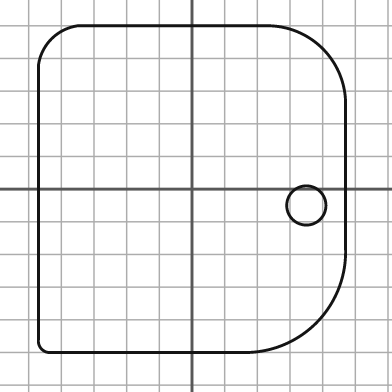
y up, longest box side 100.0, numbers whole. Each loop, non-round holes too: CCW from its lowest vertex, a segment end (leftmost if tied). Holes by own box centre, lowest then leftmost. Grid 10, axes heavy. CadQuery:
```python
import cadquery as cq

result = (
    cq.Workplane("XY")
    .moveTo(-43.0, -50.0)
    .lineTo(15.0, -50.0)
    .threePointArc((38.0, -41.0), (47.0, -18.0))
    .lineTo(47.0, 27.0)
    .threePointArc((40.0, 43.0), (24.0, 50.0))
    .lineTo(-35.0, 50.0)
    .threePointArc((-43.0, 46.0), (-47.0, 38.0))
    .lineTo(-47.0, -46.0)
    .threePointArc((-46.0, -49.0), (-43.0, -50.0))
    .close()
    .moveTo(35.0, -5.0)
    .circle(6.0)
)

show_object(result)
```